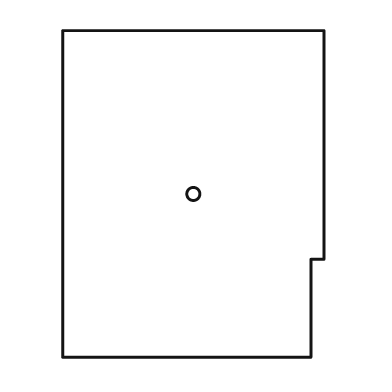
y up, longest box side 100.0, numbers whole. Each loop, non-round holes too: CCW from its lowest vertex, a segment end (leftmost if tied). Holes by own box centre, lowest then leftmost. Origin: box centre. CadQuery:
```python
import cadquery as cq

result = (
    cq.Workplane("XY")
    .moveTo(-40.0, -50.0)
    .lineTo(36.0, -50.0)
    .lineTo(36.0, -20.0)
    .lineTo(40.0, -20.0)
    .lineTo(40.0, 50.0)
    .lineTo(-40.0, 50.0)
    .close()
    .moveTo(0.0, 0.0)
    .circle(2.0)
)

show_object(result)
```